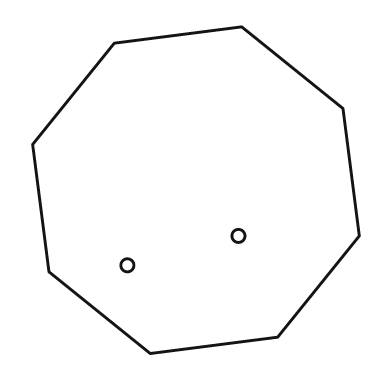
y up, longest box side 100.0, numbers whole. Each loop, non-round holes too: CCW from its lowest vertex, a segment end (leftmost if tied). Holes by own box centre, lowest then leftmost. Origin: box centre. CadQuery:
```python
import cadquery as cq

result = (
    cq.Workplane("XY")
    .moveTo(-14.0, -50.0)
    .lineTo(25.0, -45.0)
    .lineTo(50.0, -14.0)
    .lineTo(45.0, 25.0)
    .lineTo(14.0, 50.0)
    .lineTo(-25.0, 45.0)
    .lineTo(-50.0, 14.0)
    .lineTo(-45.0, -25.0)
    .close()
    .moveTo(-21.0, -23.0)
    .circle(2.0)
    .moveTo(13.0, -14.0)
    .circle(2.0)
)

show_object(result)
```